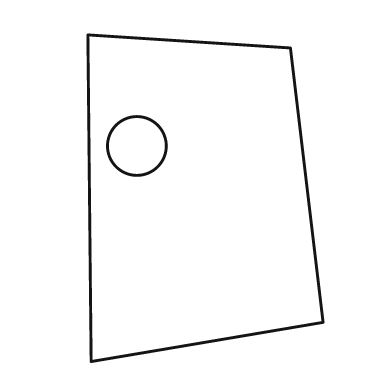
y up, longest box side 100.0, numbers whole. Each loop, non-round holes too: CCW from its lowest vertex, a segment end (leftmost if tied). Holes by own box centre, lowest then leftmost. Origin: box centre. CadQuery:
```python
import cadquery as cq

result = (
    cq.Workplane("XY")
    .moveTo(-35.0, -50.0)
    .lineTo(36.0, -38.0)
    .lineTo(26.0, 46.0)
    .lineTo(-36.0, 50.0)
    .close()
    .moveTo(-21.0, 16.0)
    .circle(9.0)
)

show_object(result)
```